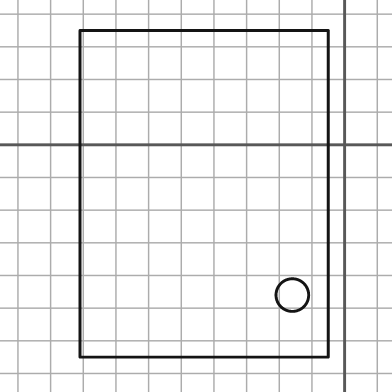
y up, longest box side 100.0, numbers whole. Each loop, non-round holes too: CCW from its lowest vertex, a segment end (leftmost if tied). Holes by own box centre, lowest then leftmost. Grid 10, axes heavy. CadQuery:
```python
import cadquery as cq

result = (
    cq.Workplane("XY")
    .moveTo(-81.0, -65.0)
    .lineTo(-5.0, -65.0)
    .lineTo(-5.0, 35.0)
    .lineTo(-81.0, 35.0)
    .close()
    .moveTo(-16.0, -46.0)
    .circle(5.0)
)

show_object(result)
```